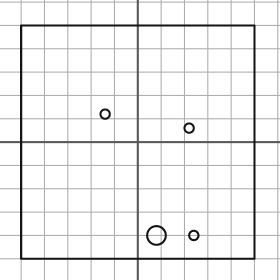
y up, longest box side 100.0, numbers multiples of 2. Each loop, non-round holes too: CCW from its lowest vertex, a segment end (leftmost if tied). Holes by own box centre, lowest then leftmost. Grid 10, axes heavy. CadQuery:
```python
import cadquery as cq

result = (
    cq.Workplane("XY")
    .moveTo(-50.0, -50.0)
    .lineTo(50.0, -50.0)
    .lineTo(50.0, 50.0)
    .lineTo(-50.0, 50.0)
    .close()
    .moveTo(8.0, -40.0)
    .circle(4.0)
    .moveTo(24.0, -40.0)
    .circle(2.0)
    .moveTo(22.0, 6.0)
    .circle(2.0)
    .moveTo(-14.0, 12.0)
    .circle(2.0)
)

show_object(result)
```